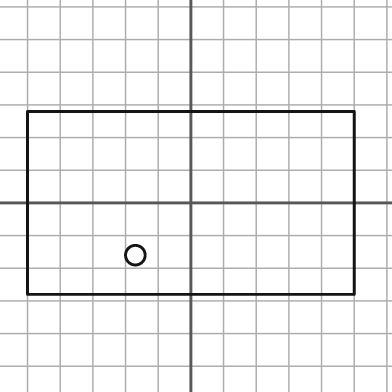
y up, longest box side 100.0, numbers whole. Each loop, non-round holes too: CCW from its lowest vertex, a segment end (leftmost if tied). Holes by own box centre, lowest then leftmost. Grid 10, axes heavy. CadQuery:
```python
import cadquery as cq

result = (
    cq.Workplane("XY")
    .moveTo(-50.0, -28.0)
    .lineTo(50.0, -28.0)
    .lineTo(50.0, 28.0)
    .lineTo(-50.0, 28.0)
    .close()
    .moveTo(-17.0, -16.0)
    .circle(3.0)
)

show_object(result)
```